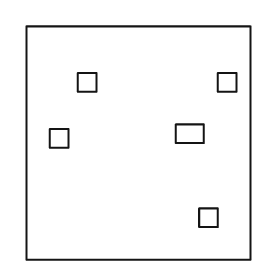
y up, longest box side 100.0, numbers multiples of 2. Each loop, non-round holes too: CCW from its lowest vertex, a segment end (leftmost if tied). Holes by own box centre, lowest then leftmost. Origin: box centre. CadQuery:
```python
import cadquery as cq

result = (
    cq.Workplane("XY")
    .moveTo(-48.0, -50.0)
    .lineTo(48.0, -50.0)
    .lineTo(48.0, 50.0)
    .lineTo(-48.0, 50.0)
    .close()
    .moveTo(26.0, -36.0)
    .lineTo(34.0, -36.0)
    .lineTo(34.0, -28.0)
    .lineTo(26.0, -28.0)
    .close()
    .moveTo(-38.0, -2.0)
    .lineTo(-30.0, -2.0)
    .lineTo(-30.0, 6.0)
    .lineTo(-38.0, 6.0)
    .close()
    .moveTo(16.0, 0.0)
    .lineTo(28.0, 0.0)
    .lineTo(28.0, 8.0)
    .lineTo(16.0, 8.0)
    .close()
    .moveTo(-26.0, 22.0)
    .lineTo(-18.0, 22.0)
    .lineTo(-18.0, 30.0)
    .lineTo(-26.0, 30.0)
    .close()
    .moveTo(34.0, 22.0)
    .lineTo(42.0, 22.0)
    .lineTo(42.0, 30.0)
    .lineTo(34.0, 30.0)
    .close()
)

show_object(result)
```